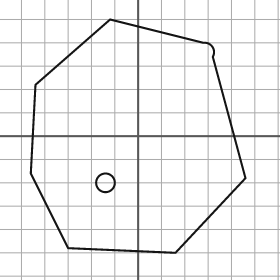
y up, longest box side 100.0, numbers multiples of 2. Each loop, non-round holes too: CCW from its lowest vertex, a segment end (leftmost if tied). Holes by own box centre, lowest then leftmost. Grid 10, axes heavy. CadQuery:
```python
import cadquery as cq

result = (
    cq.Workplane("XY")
    .moveTo(16.0, -50.0)
    .lineTo(46.0, -18.0)
    .lineTo(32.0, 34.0)
    .threePointArc((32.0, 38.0), (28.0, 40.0))
    .lineTo(-12.0, 50.0)
    .lineTo(-44.0, 22.0)
    .lineTo(-46.0, -16.0)
    .lineTo(-30.0, -48.0)
    .close()
    .moveTo(-14.0, -20.0)
    .circle(4.0)
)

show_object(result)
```